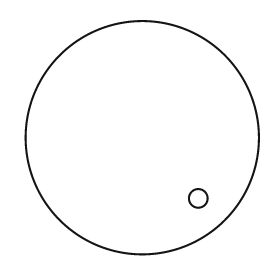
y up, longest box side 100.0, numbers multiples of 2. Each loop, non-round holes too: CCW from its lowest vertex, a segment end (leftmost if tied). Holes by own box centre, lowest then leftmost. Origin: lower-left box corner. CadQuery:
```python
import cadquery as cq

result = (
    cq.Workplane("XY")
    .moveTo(50.0, 50.0)
    .circle(50.0)
    .moveTo(74.0, 24.0)
    .circle(4.0)
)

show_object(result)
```